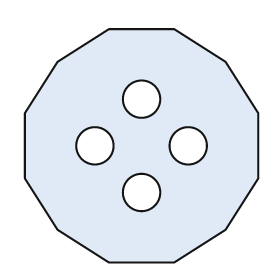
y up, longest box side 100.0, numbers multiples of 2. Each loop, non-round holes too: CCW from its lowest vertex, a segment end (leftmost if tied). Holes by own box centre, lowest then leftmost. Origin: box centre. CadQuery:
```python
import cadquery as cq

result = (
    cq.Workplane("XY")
    .moveTo(-14.0, -50.0)
    .lineTo(14.0, -50.0)
    .lineTo(36.0, -36.0)
    .lineTo(50.0, -14.0)
    .lineTo(50.0, 14.0)
    .lineTo(36.0, 36.0)
    .lineTo(14.0, 50.0)
    .lineTo(-14.0, 50.0)
    .lineTo(-36.0, 36.0)
    .lineTo(-50.0, 14.0)
    .lineTo(-50.0, -14.0)
    .lineTo(-36.0, -36.0)
    .close()
    .moveTo(0.0, -20.0)
    .circle(8.0)
    .moveTo(-20.0, 0.0)
    .circle(8.0)
    .moveTo(20.0, 0.0)
    .circle(8.0)
    .moveTo(0.0, 20.0)
    .circle(8.0)
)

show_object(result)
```